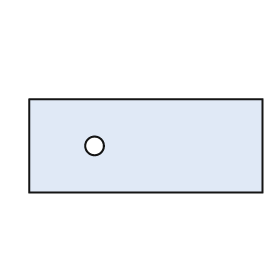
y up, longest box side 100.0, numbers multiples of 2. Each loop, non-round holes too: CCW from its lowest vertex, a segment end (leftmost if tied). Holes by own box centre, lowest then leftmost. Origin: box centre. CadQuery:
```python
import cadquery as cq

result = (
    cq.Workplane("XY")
    .moveTo(-50.0, -20.0)
    .lineTo(50.0, -20.0)
    .lineTo(50.0, 20.0)
    .lineTo(-50.0, 20.0)
    .close()
    .moveTo(-22.0, 0.0)
    .circle(4.0)
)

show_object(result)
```